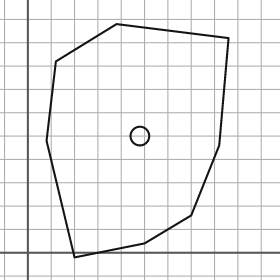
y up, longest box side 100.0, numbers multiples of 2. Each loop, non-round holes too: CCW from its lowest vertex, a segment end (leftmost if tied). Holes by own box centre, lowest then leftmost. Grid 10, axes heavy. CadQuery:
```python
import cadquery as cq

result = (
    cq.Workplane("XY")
    .moveTo(20.0, -2.0)
    .lineTo(50.0, 4.0)
    .lineTo(70.0, 16.0)
    .lineTo(82.0, 46.0)
    .lineTo(86.0, 92.0)
    .lineTo(38.0, 98.0)
    .lineTo(12.0, 82.0)
    .lineTo(8.0, 48.0)
    .close()
    .moveTo(48.0, 50.0)
    .circle(4.0)
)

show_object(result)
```